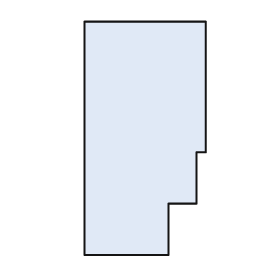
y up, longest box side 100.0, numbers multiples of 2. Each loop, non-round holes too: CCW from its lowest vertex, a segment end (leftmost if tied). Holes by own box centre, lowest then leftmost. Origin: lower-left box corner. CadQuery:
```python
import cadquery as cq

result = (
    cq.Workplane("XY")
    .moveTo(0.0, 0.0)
    .lineTo(36.0, 0.0)
    .lineTo(36.0, 22.0)
    .lineTo(48.0, 22.0)
    .lineTo(48.0, 44.0)
    .lineTo(52.0, 44.0)
    .lineTo(52.0, 100.0)
    .lineTo(0.0, 100.0)
    .close()
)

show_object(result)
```